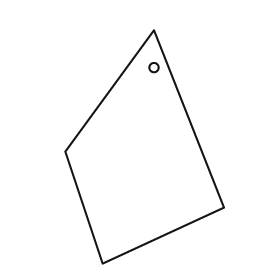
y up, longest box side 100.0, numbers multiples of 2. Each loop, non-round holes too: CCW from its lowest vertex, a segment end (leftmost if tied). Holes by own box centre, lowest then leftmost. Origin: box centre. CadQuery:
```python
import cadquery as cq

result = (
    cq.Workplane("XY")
    .moveTo(-18.0, -50.0)
    .lineTo(34.0, -26.0)
    .lineTo(4.0, 50.0)
    .lineTo(-34.0, -2.0)
    .close()
    .moveTo(4.0, 34.0)
    .circle(2.0)
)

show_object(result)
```